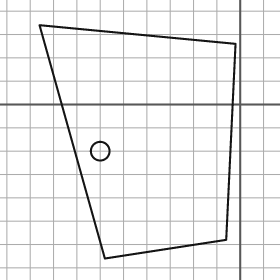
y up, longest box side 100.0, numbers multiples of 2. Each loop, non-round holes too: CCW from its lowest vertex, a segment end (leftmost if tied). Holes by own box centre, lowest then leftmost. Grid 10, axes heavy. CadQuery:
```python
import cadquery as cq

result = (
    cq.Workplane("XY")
    .moveTo(-58.0, -66.0)
    .lineTo(-6.0, -58.0)
    .lineTo(-2.0, 26.0)
    .lineTo(-86.0, 34.0)
    .close()
    .moveTo(-60.0, -20.0)
    .circle(4.0)
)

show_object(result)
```